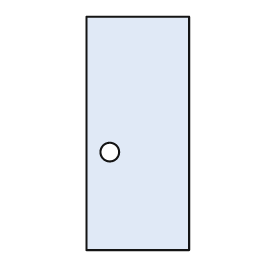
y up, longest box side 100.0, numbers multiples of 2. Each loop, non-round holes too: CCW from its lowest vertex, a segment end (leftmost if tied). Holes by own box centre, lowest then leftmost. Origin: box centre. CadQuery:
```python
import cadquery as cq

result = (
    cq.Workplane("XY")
    .moveTo(-22.0, -50.0)
    .lineTo(22.0, -50.0)
    .lineTo(22.0, 50.0)
    .lineTo(-22.0, 50.0)
    .close()
    .moveTo(-12.0, -8.0)
    .circle(4.0)
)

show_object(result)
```